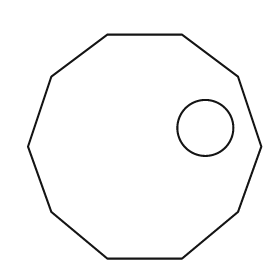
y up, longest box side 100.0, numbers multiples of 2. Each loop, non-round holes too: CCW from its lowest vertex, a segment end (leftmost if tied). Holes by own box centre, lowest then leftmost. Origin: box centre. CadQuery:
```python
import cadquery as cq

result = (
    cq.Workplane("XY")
    .moveTo(-16.0, -48.0)
    .lineTo(16.0, -48.0)
    .lineTo(40.0, -28.0)
    .lineTo(50.0, 0.0)
    .lineTo(40.0, 30.0)
    .lineTo(16.0, 48.0)
    .lineTo(-16.0, 48.0)
    .lineTo(-40.0, 30.0)
    .lineTo(-50.0, 0.0)
    .lineTo(-40.0, -28.0)
    .close()
    .moveTo(26.0, 8.0)
    .circle(12.0)
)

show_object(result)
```